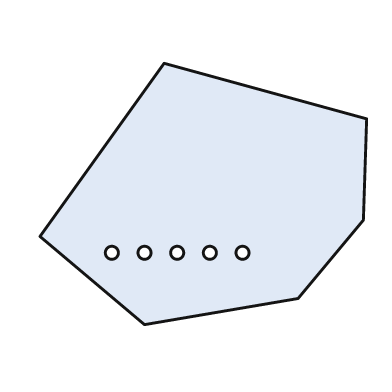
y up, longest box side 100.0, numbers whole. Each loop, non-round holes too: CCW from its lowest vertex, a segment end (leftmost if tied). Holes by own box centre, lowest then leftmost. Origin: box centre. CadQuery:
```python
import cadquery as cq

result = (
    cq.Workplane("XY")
    .moveTo(-18.0, -40.0)
    .lineTo(29.0, -32.0)
    .lineTo(49.0, -8.0)
    .lineTo(50.0, 23.0)
    .lineTo(-12.0, 40.0)
    .lineTo(-50.0, -13.0)
    .close()
    .moveTo(-28.0, -18.0)
    .circle(2.0)
    .moveTo(-18.0, -18.0)
    .circle(2.0)
    .moveTo(-8.0, -18.0)
    .circle(2.0)
    .moveTo(2.0, -18.0)
    .circle(2.0)
    .moveTo(12.0, -18.0)
    .circle(2.0)
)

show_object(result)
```